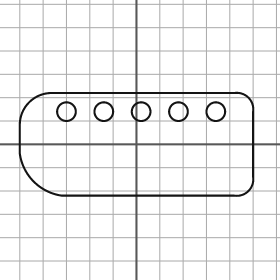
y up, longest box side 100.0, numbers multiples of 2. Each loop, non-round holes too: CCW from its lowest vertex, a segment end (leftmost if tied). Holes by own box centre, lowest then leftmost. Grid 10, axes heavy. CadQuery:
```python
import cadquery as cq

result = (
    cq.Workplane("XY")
    .moveTo(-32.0, -22.0)
    .lineTo(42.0, -22.0)
    .threePointArc((48.0, -20.0), (50.0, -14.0))
    .lineTo(50.0, 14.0)
    .threePointArc((48.0, 20.0), (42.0, 22.0))
    .lineTo(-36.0, 22.0)
    .threePointArc((-46.0, 18.0), (-50.0, 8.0))
    .lineTo(-50.0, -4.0)
    .threePointArc((-44.0, -16.0), (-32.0, -22.0))
    .close()
    .moveTo(-30.0, 14.0)
    .circle(4.0)
    .moveTo(-14.0, 14.0)
    .circle(4.0)
    .moveTo(2.0, 14.0)
    .circle(4.0)
    .moveTo(18.0, 14.0)
    .circle(4.0)
    .moveTo(34.0, 14.0)
    .circle(4.0)
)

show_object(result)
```